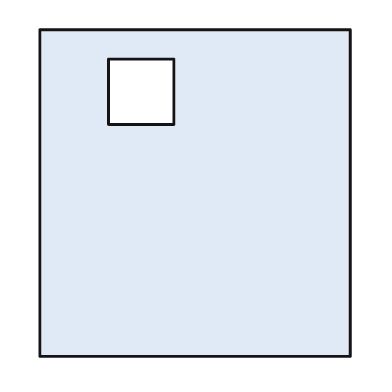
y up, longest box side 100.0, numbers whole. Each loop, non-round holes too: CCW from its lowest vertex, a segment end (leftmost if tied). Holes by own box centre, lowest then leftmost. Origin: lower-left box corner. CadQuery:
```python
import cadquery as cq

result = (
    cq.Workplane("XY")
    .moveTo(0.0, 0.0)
    .lineTo(95.0, 0.0)
    .lineTo(95.0, 100.0)
    .lineTo(0.0, 100.0)
    .close()
    .moveTo(21.0, 71.0)
    .lineTo(41.0, 71.0)
    .lineTo(41.0, 91.0)
    .lineTo(21.0, 91.0)
    .close()
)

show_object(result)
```